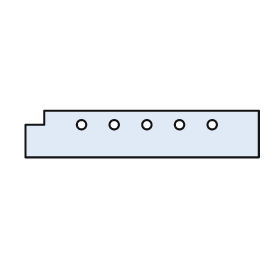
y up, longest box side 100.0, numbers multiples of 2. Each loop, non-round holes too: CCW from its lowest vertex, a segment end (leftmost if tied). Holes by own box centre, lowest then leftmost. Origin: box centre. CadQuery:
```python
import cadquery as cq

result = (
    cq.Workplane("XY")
    .moveTo(-50.0, -10.0)
    .lineTo(50.0, -10.0)
    .lineTo(50.0, 10.0)
    .lineTo(-42.0, 10.0)
    .lineTo(-42.0, 4.0)
    .lineTo(-50.0, 4.0)
    .close()
    .moveTo(-26.0, 4.0)
    .circle(2.0)
    .moveTo(-12.0, 4.0)
    .circle(2.0)
    .moveTo(2.0, 4.0)
    .circle(2.0)
    .moveTo(16.0, 4.0)
    .circle(2.0)
    .moveTo(30.0, 4.0)
    .circle(2.0)
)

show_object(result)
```